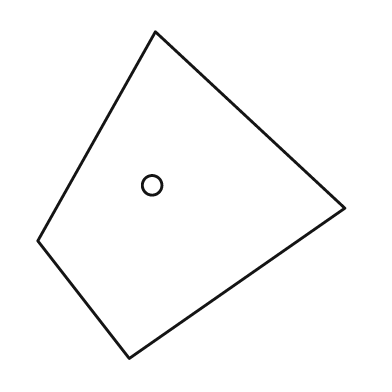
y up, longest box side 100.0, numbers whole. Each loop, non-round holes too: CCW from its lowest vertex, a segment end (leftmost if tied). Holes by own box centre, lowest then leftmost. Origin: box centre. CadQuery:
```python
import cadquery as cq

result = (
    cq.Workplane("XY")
    .moveTo(-19.0, -50.0)
    .lineTo(47.0, -4.0)
    .lineTo(-11.0, 50.0)
    .lineTo(-47.0, -14.0)
    .close()
    .moveTo(-12.0, 3.0)
    .circle(3.0)
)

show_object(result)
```